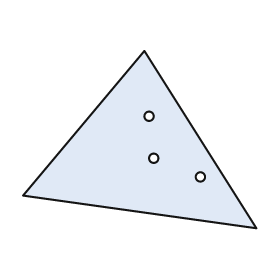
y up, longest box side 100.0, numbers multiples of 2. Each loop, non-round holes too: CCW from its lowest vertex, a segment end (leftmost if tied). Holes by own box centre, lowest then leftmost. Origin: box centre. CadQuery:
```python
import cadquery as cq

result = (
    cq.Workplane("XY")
    .moveTo(50.0, -38.0)
    .lineTo(2.0, 38.0)
    .lineTo(-50.0, -24.0)
    .close()
    .moveTo(26.0, -16.0)
    .circle(2.0)
    .moveTo(6.0, -8.0)
    .circle(2.0)
    .moveTo(4.0, 10.0)
    .circle(2.0)
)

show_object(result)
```